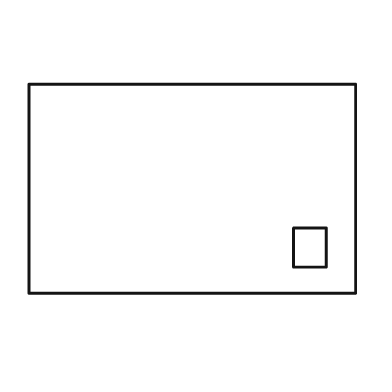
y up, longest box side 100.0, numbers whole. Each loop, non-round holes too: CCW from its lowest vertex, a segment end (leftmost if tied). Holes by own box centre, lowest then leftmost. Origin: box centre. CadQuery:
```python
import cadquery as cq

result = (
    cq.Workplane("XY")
    .moveTo(-50.0, -32.0)
    .lineTo(50.0, -32.0)
    .lineTo(50.0, 32.0)
    .lineTo(-50.0, 32.0)
    .close()
    .moveTo(31.0, -24.0)
    .lineTo(41.0, -24.0)
    .lineTo(41.0, -12.0)
    .lineTo(31.0, -12.0)
    .close()
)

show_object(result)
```